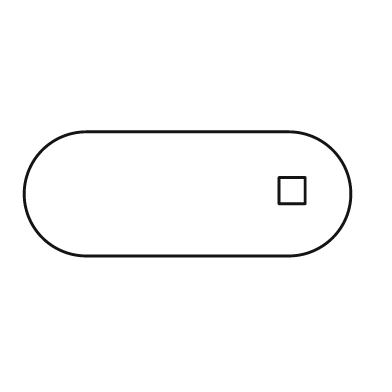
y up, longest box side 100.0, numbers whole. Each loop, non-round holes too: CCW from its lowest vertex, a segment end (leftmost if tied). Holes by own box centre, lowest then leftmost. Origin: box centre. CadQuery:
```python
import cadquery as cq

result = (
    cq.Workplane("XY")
    .moveTo(-31.0, -19.0)
    .lineTo(31.0, -19.0)
    .threePointArc((50.0, 0.0), (31.0, 19.0))
    .lineTo(-31.0, 19.0)
    .threePointArc((-50.0, 0.0), (-31.0, -19.0))
    .close()
    .moveTo(28.0, -3.0)
    .lineTo(36.0, -3.0)
    .lineTo(36.0, 5.0)
    .lineTo(28.0, 5.0)
    .close()
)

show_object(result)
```